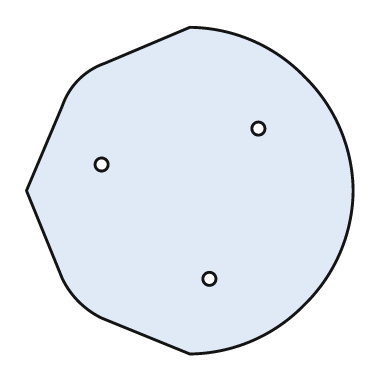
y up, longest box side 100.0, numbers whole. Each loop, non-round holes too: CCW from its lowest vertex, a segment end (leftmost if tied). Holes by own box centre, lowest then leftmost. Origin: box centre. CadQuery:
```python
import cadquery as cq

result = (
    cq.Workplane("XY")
    .moveTo(0.0, -50.0)
    .threePointArc((19.0, -46.0), (35.0, -35.0))
    .threePointArc((46.0, -19.0), (50.0, 0.0))
    .threePointArc((46.0, 19.0), (35.0, 35.0))
    .threePointArc((19.0, 46.0), (0.0, 50.0))
    .lineTo(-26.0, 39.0)
    .threePointArc((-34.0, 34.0), (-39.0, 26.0))
    .lineTo(-50.0, 0.0)
    .lineTo(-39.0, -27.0)
    .threePointArc((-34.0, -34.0), (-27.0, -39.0))
    .close()
    .moveTo(6.0, -27.0)
    .circle(2.0)
    .moveTo(-27.0, 8.0)
    .circle(2.0)
    .moveTo(21.0, 19.0)
    .circle(2.0)
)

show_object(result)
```